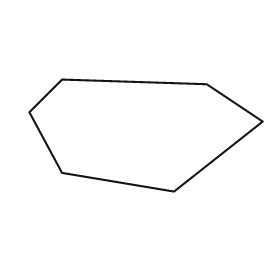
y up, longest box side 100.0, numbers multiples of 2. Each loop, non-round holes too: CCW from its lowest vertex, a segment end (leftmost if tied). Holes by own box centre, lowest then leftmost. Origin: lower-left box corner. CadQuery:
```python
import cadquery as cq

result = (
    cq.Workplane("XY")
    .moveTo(62.0, 0.0)
    .lineTo(100.0, 30.0)
    .lineTo(76.0, 46.0)
    .lineTo(14.0, 48.0)
    .lineTo(0.0, 34.0)
    .lineTo(14.0, 8.0)
    .close()
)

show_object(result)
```